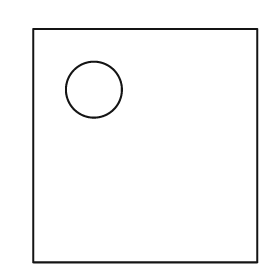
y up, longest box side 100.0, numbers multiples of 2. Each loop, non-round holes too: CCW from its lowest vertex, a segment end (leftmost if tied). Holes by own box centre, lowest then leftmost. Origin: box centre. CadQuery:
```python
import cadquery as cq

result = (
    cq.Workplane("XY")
    .moveTo(-48.0, -50.0)
    .lineTo(48.0, -50.0)
    .lineTo(48.0, 50.0)
    .lineTo(-48.0, 50.0)
    .close()
    .moveTo(-22.0, 24.0)
    .circle(12.0)
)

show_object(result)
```